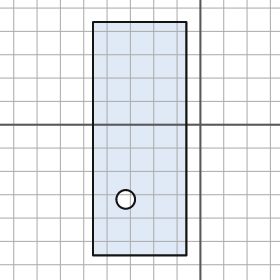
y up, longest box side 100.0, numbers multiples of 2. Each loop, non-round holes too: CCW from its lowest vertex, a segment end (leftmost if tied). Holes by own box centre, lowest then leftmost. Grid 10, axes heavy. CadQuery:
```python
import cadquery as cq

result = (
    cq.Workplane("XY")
    .moveTo(-46.0, -56.0)
    .lineTo(-6.0, -56.0)
    .lineTo(-6.0, 44.0)
    .lineTo(-46.0, 44.0)
    .close()
    .moveTo(-32.0, -32.0)
    .circle(4.0)
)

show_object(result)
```